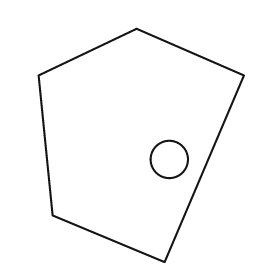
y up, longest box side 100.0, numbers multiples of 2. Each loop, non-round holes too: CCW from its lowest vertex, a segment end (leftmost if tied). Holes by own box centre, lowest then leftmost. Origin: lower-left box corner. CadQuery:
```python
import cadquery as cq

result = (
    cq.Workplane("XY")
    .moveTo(54.0, 0.0)
    .lineTo(88.0, 80.0)
    .lineTo(42.0, 100.0)
    .lineTo(0.0, 80.0)
    .lineTo(6.0, 20.0)
    .close()
    .moveTo(56.0, 44.0)
    .circle(8.0)
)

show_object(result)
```